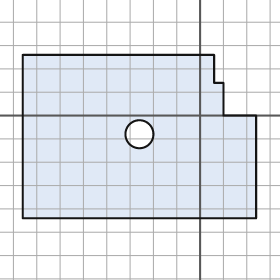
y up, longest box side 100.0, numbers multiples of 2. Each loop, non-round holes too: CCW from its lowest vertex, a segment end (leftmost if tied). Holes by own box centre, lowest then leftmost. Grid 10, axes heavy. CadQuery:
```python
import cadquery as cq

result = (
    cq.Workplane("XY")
    .moveTo(-76.0, -44.0)
    .lineTo(24.0, -44.0)
    .lineTo(24.0, 0.0)
    .lineTo(10.0, 0.0)
    .lineTo(10.0, 14.0)
    .lineTo(6.0, 14.0)
    .lineTo(6.0, 26.0)
    .lineTo(-76.0, 26.0)
    .close()
    .moveTo(-26.0, -8.0)
    .circle(6.0)
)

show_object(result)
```